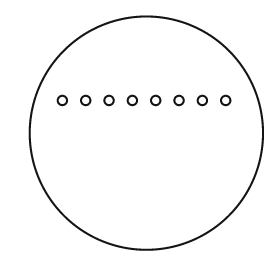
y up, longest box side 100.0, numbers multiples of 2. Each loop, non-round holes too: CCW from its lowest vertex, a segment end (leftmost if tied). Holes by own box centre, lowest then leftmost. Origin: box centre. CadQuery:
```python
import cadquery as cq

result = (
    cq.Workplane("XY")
    .moveTo(0.0, 0.0)
    .circle(50.0)
    .moveTo(-36.0, 14.0)
    .circle(2.0)
    .moveTo(-26.0, 14.0)
    .circle(2.0)
    .moveTo(-16.0, 14.0)
    .circle(2.0)
    .moveTo(-6.0, 14.0)
    .circle(2.0)
    .moveTo(4.0, 14.0)
    .circle(2.0)
    .moveTo(14.0, 14.0)
    .circle(2.0)
    .moveTo(24.0, 14.0)
    .circle(2.0)
    .moveTo(34.0, 14.0)
    .circle(2.0)
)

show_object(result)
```